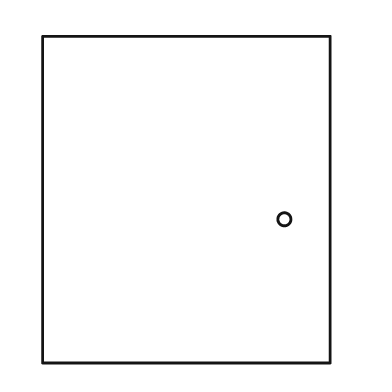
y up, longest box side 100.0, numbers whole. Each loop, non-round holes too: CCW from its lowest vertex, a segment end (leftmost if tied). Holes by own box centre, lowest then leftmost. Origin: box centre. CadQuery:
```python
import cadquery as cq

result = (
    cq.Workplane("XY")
    .moveTo(-44.0, -50.0)
    .lineTo(44.0, -50.0)
    .lineTo(44.0, 50.0)
    .lineTo(-44.0, 50.0)
    .close()
    .moveTo(30.0, -6.0)
    .circle(2.0)
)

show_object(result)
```